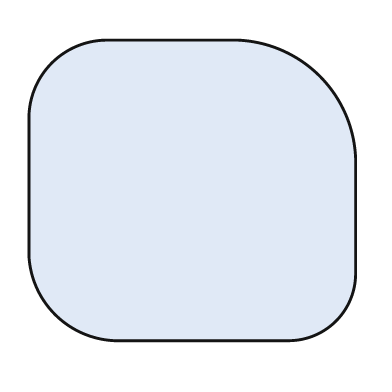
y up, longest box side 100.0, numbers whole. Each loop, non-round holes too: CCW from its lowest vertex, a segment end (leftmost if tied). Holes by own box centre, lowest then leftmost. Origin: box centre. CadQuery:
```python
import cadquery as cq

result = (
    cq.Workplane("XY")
    .moveTo(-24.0, -46.0)
    .lineTo(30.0, -46.0)
    .threePointArc((44.0, -40.0), (50.0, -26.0))
    .lineTo(50.0, 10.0)
    .threePointArc((39.0, 35.0), (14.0, 46.0))
    .lineTo(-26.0, 46.0)
    .threePointArc((-43.0, 39.0), (-50.0, 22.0))
    .lineTo(-50.0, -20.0)
    .threePointArc((-42.0, -38.0), (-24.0, -46.0))
    .close()
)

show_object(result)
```